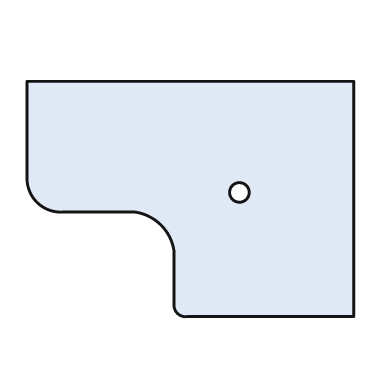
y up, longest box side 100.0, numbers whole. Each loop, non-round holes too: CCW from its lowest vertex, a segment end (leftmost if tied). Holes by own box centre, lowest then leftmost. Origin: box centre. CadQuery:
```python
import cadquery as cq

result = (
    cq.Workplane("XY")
    .moveTo(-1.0, -36.0)
    .lineTo(50.0, -36.0)
    .lineTo(50.0, 36.0)
    .lineTo(-50.0, 36.0)
    .lineTo(-50.0, 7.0)
    .threePointArc((-47.0, -1.0), (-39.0, -4.0))
    .lineTo(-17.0, -4.0)
    .threePointArc((-9.0, -8.0), (-5.0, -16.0))
    .lineTo(-5.0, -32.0)
    .threePointArc((-4.0, -35.0), (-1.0, -36.0))
    .close()
    .moveTo(15.0, 2.0)
    .circle(3.0)
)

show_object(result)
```